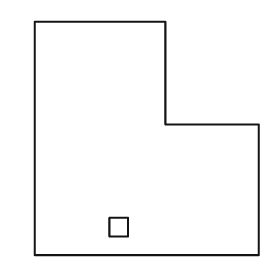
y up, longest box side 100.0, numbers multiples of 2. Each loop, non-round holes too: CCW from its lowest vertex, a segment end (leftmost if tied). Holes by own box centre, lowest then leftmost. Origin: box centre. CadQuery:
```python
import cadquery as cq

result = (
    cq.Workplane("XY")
    .moveTo(-48.0, -50.0)
    .lineTo(48.0, -50.0)
    .lineTo(48.0, 6.0)
    .lineTo(8.0, 6.0)
    .lineTo(8.0, 50.0)
    .lineTo(-48.0, 50.0)
    .close()
    .moveTo(-16.0, -42.0)
    .lineTo(-8.0, -42.0)
    .lineTo(-8.0, -34.0)
    .lineTo(-16.0, -34.0)
    .close()
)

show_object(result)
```